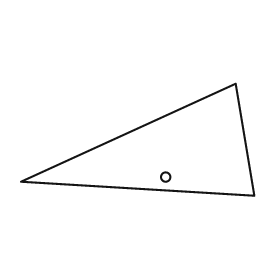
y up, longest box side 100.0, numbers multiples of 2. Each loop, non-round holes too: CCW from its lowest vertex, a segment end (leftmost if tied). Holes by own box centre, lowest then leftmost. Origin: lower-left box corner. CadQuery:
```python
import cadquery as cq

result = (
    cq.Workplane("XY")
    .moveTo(100.0, 0.0)
    .lineTo(92.0, 48.0)
    .lineTo(0.0, 6.0)
    .close()
    .moveTo(62.0, 8.0)
    .circle(2.0)
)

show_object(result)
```